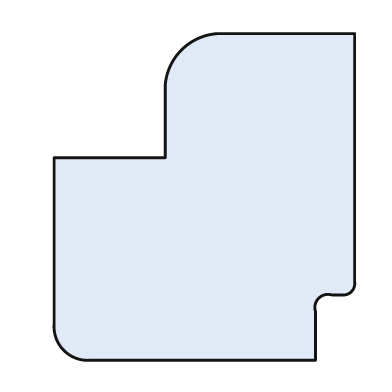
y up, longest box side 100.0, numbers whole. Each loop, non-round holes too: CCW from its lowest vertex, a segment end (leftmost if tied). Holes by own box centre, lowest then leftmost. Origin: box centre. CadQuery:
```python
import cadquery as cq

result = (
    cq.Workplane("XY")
    .moveTo(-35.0, -50.0)
    .lineTo(34.0, -50.0)
    .lineTo(34.0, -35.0)
    .threePointArc((35.0, -31.0), (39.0, -30.0))
    .lineTo(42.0, -30.0)
    .threePointArc((45.0, -29.0), (46.0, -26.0))
    .lineTo(46.0, 50.0)
    .lineTo(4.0, 50.0)
    .threePointArc((-7.0, 45.0), (-12.0, 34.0))
    .lineTo(-12.0, 12.0)
    .lineTo(-46.0, 12.0)
    .lineTo(-46.0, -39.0)
    .threePointArc((-43.0, -47.0), (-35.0, -50.0))
    .close()
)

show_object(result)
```